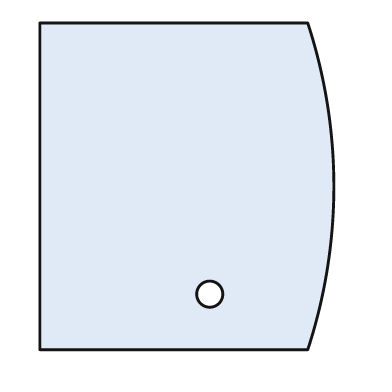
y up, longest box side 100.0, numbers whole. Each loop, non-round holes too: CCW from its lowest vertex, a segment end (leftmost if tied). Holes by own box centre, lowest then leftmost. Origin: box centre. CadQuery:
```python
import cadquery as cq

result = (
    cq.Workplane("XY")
    .moveTo(-45.0, -50.0)
    .lineTo(37.0, -50.0)
    .threePointArc((45.0, 0.0), (37.0, 50.0))
    .lineTo(-45.0, 50.0)
    .close()
    .moveTo(7.0, -33.0)
    .circle(4.0)
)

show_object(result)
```